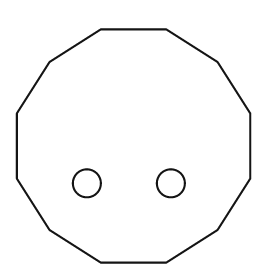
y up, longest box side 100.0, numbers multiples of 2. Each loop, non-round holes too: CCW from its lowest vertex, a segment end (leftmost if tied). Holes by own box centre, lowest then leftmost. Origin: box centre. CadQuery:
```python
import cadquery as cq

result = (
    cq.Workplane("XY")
    .moveTo(-14.0, -50.0)
    .lineTo(14.0, -50.0)
    .lineTo(36.0, -36.0)
    .lineTo(50.0, -14.0)
    .lineTo(50.0, 14.0)
    .lineTo(36.0, 36.0)
    .lineTo(14.0, 50.0)
    .lineTo(-14.0, 50.0)
    .lineTo(-36.0, 36.0)
    .lineTo(-50.0, 14.0)
    .lineTo(-50.0, -14.0)
    .lineTo(-36.0, -36.0)
    .close()
    .moveTo(-20.0, -16.0)
    .circle(6.0)
    .moveTo(16.0, -16.0)
    .circle(6.0)
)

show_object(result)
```